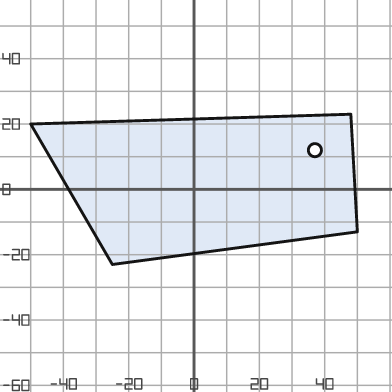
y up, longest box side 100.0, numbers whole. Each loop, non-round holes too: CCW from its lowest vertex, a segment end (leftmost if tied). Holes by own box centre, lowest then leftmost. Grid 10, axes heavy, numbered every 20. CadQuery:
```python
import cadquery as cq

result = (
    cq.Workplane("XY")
    .moveTo(-25.0, -23.0)
    .lineTo(50.0, -13.0)
    .lineTo(48.0, 23.0)
    .lineTo(-50.0, 20.0)
    .close()
    .moveTo(37.0, 12.0)
    .circle(2.0)
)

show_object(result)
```